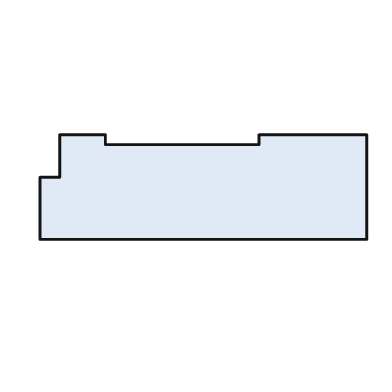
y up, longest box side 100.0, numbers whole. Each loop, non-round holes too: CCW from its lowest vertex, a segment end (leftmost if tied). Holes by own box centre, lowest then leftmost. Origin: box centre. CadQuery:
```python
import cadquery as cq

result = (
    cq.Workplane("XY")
    .moveTo(-50.0, -16.0)
    .lineTo(50.0, -16.0)
    .lineTo(50.0, 16.0)
    .lineTo(17.0, 16.0)
    .lineTo(17.0, 13.0)
    .lineTo(-30.0, 13.0)
    .lineTo(-30.0, 16.0)
    .lineTo(-44.0, 16.0)
    .lineTo(-44.0, 3.0)
    .lineTo(-50.0, 3.0)
    .close()
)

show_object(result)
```